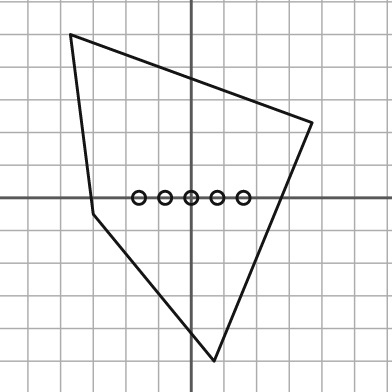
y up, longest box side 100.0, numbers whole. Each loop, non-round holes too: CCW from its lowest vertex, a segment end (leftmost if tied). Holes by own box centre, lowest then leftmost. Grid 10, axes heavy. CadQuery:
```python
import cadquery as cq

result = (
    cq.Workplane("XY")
    .moveTo(7.0, -50.0)
    .lineTo(37.0, 23.0)
    .lineTo(-37.0, 50.0)
    .lineTo(-30.0, -5.0)
    .close()
    .moveTo(-16.0, 0.0)
    .circle(2.0)
    .moveTo(-8.0, 0.0)
    .circle(2.0)
    .moveTo(0.0, 0.0)
    .circle(2.0)
    .moveTo(8.0, 0.0)
    .circle(2.0)
    .moveTo(16.0, 0.0)
    .circle(2.0)
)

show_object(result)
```